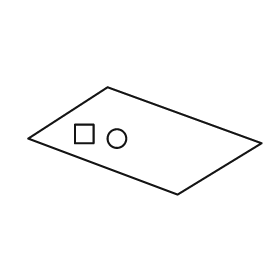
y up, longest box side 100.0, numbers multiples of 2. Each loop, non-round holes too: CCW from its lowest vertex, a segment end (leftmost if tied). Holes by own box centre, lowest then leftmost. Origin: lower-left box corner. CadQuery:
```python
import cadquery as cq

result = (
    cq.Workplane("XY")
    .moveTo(64.0, 0.0)
    .lineTo(100.0, 22.0)
    .lineTo(34.0, 46.0)
    .lineTo(0.0, 24.0)
    .close()
    .moveTo(38.0, 24.0)
    .circle(4.0)
    .moveTo(20.0, 22.0)
    .lineTo(28.0, 22.0)
    .lineTo(28.0, 30.0)
    .lineTo(20.0, 30.0)
    .close()
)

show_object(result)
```